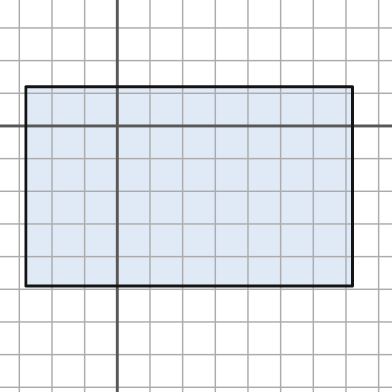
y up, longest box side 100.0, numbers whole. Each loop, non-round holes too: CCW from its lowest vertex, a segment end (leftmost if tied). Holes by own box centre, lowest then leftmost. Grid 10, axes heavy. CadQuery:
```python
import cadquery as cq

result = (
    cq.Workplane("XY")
    .moveTo(-28.0, -49.0)
    .lineTo(72.0, -49.0)
    .lineTo(72.0, 12.0)
    .lineTo(-28.0, 12.0)
    .close()
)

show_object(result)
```